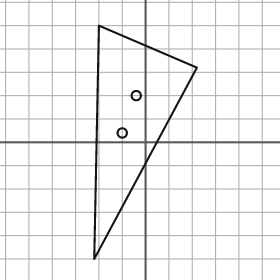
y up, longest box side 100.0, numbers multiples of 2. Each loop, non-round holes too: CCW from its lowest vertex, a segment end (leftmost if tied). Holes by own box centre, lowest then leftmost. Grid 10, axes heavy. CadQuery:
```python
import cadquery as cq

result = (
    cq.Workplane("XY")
    .moveTo(-22.0, -50.0)
    .lineTo(22.0, 32.0)
    .lineTo(-20.0, 50.0)
    .close()
    .moveTo(-10.0, 4.0)
    .circle(2.0)
    .moveTo(-4.0, 20.0)
    .circle(2.0)
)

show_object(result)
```